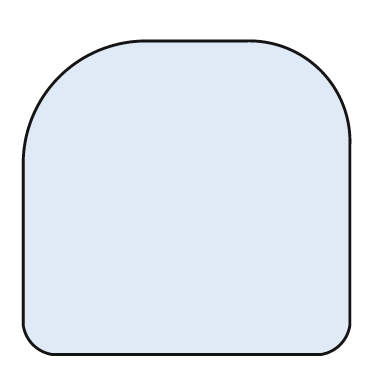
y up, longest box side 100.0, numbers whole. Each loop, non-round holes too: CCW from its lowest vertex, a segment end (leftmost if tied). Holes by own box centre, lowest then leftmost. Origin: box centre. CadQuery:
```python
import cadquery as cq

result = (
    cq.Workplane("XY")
    .moveTo(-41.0, -48.0)
    .lineTo(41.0, -48.0)
    .threePointArc((47.0, -45.0), (50.0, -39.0))
    .lineTo(50.0, 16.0)
    .threePointArc((41.0, 39.0), (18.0, 48.0))
    .lineTo(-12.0, 48.0)
    .threePointArc((-39.0, 37.0), (-50.0, 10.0))
    .lineTo(-50.0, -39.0)
    .threePointArc((-47.0, -45.0), (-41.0, -48.0))
    .close()
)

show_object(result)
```